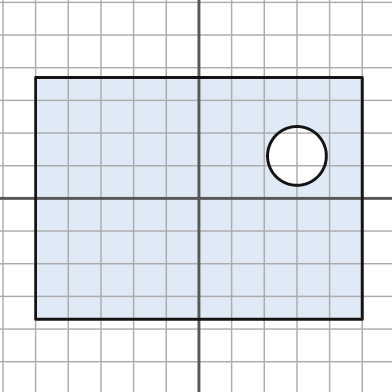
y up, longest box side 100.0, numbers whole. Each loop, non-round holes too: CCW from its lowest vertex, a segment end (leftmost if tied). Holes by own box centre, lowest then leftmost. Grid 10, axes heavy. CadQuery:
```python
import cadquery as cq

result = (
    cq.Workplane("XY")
    .moveTo(-50.0, -37.0)
    .lineTo(50.0, -37.0)
    .lineTo(50.0, 37.0)
    .lineTo(-50.0, 37.0)
    .close()
    .moveTo(30.0, 13.0)
    .circle(9.0)
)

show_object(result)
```